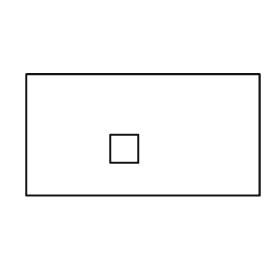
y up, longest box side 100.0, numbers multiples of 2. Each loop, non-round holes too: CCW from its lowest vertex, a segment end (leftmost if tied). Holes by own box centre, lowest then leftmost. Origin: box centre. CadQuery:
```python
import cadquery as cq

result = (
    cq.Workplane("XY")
    .moveTo(-50.0, -26.0)
    .lineTo(50.0, -26.0)
    .lineTo(50.0, 26.0)
    .lineTo(-50.0, 26.0)
    .close()
    .moveTo(-14.0, -12.0)
    .lineTo(-2.0, -12.0)
    .lineTo(-2.0, 0.0)
    .lineTo(-14.0, 0.0)
    .close()
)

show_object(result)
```